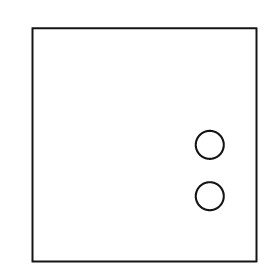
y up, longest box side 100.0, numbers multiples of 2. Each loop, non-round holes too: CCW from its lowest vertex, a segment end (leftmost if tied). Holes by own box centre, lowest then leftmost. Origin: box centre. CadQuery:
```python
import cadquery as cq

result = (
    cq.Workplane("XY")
    .moveTo(-48.0, -50.0)
    .lineTo(48.0, -50.0)
    .lineTo(48.0, 50.0)
    .lineTo(-48.0, 50.0)
    .close()
    .moveTo(28.0, -22.0)
    .circle(6.0)
    .moveTo(28.0, 0.0)
    .circle(6.0)
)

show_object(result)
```